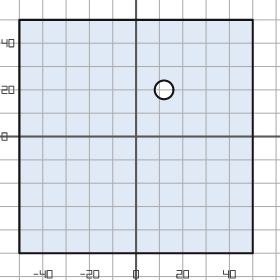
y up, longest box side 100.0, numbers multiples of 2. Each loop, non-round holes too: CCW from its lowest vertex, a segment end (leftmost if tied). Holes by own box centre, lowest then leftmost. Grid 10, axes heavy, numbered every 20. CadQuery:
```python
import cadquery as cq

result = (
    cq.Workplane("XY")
    .moveTo(-50.0, -50.0)
    .lineTo(50.0, -50.0)
    .lineTo(50.0, 50.0)
    .lineTo(-50.0, 50.0)
    .close()
    .moveTo(12.0, 20.0)
    .circle(4.0)
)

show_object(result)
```